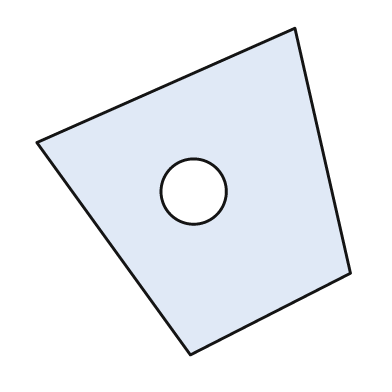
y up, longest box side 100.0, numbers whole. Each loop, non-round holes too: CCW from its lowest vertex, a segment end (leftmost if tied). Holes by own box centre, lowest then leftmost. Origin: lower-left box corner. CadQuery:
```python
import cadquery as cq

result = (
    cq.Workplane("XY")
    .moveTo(47.0, 0.0)
    .lineTo(96.0, 25.0)
    .lineTo(79.0, 100.0)
    .lineTo(0.0, 65.0)
    .close()
    .moveTo(48.0, 50.0)
    .circle(10.0)
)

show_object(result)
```